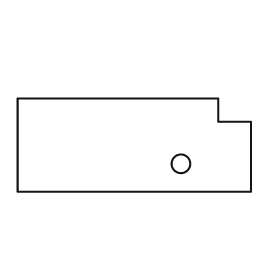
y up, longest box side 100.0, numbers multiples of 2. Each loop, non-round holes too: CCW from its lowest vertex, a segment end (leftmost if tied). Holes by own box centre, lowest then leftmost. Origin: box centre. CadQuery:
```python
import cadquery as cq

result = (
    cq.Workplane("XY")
    .moveTo(-50.0, -20.0)
    .lineTo(50.0, -20.0)
    .lineTo(50.0, 10.0)
    .lineTo(36.0, 10.0)
    .lineTo(36.0, 20.0)
    .lineTo(-50.0, 20.0)
    .close()
    .moveTo(20.0, -8.0)
    .circle(4.0)
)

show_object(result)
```